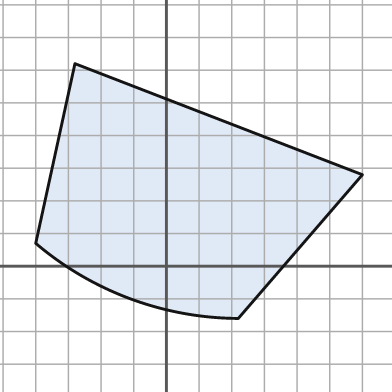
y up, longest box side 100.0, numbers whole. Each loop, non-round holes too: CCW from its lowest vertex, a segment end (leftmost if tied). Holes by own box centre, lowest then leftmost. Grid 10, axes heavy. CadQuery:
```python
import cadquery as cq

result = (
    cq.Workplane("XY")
    .moveTo(22.0, -16.0)
    .lineTo(60.0, 28.0)
    .lineTo(-28.0, 62.0)
    .lineTo(-40.0, 7.0)
    .threePointArc((-11.0, -10.0), (22.0, -16.0))
    .close()
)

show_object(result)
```